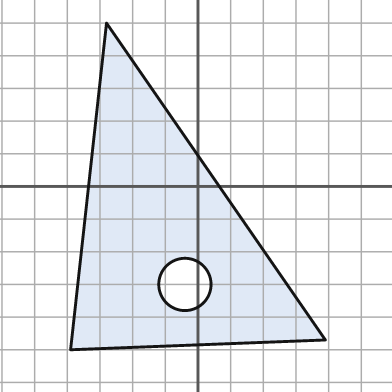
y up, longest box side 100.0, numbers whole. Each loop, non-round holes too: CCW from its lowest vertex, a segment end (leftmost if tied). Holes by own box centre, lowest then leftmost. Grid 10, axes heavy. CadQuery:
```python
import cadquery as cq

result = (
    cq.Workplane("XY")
    .moveTo(-39.0, -50.0)
    .lineTo(39.0, -47.0)
    .lineTo(-28.0, 50.0)
    .close()
    .moveTo(-4.0, -30.0)
    .circle(8.0)
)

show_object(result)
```